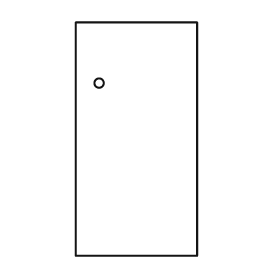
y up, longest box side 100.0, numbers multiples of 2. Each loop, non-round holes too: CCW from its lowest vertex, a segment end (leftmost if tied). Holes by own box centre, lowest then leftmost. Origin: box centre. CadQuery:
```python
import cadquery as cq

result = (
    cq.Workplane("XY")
    .moveTo(-26.0, -50.0)
    .lineTo(26.0, -50.0)
    .lineTo(26.0, 50.0)
    .lineTo(-26.0, 50.0)
    .close()
    .moveTo(-16.0, 24.0)
    .circle(2.0)
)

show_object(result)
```